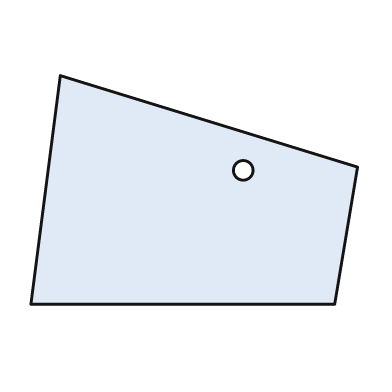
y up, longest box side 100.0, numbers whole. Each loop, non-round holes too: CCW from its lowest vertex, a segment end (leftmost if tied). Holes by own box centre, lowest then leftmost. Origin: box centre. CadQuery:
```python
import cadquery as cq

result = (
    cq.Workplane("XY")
    .moveTo(-50.0, -35.0)
    .lineTo(43.0, -35.0)
    .lineTo(50.0, 7.0)
    .lineTo(-41.0, 35.0)
    .close()
    .moveTo(15.0, 6.0)
    .circle(3.0)
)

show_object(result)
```